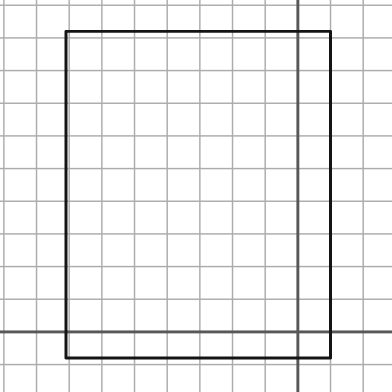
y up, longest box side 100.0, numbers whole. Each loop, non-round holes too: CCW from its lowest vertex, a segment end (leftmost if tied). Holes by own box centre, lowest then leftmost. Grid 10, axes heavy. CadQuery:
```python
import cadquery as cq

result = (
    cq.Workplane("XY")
    .moveTo(-71.0, -8.0)
    .lineTo(10.0, -8.0)
    .lineTo(10.0, 92.0)
    .lineTo(-71.0, 92.0)
    .close()
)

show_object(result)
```